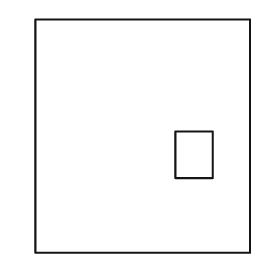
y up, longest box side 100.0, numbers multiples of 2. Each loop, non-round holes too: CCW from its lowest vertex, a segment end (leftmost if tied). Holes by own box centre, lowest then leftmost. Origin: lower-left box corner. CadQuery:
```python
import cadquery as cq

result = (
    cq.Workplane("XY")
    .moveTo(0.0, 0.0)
    .lineTo(92.0, 0.0)
    .lineTo(92.0, 100.0)
    .lineTo(0.0, 100.0)
    .close()
    .moveTo(60.0, 32.0)
    .lineTo(76.0, 32.0)
    .lineTo(76.0, 52.0)
    .lineTo(60.0, 52.0)
    .close()
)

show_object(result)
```